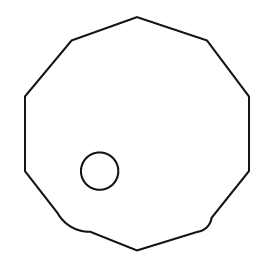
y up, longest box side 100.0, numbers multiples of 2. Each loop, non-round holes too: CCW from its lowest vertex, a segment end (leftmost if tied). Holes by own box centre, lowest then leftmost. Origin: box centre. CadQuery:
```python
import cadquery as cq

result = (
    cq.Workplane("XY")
    .moveTo(0.0, -50.0)
    .lineTo(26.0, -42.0)
    .threePointArc((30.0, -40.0), (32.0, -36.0))
    .lineTo(48.0, -16.0)
    .lineTo(48.0, 16.0)
    .lineTo(30.0, 40.0)
    .lineTo(0.0, 50.0)
    .lineTo(-28.0, 40.0)
    .lineTo(-48.0, 16.0)
    .lineTo(-48.0, -16.0)
    .lineTo(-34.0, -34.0)
    .threePointArc((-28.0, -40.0), (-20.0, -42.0))
    .close()
    .moveTo(-16.0, -16.0)
    .circle(8.0)
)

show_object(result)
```